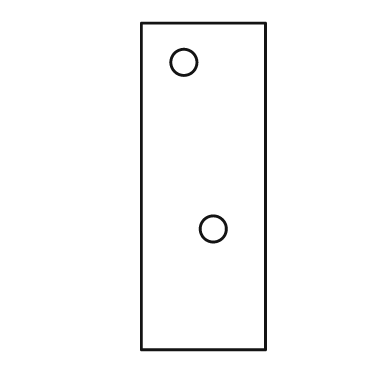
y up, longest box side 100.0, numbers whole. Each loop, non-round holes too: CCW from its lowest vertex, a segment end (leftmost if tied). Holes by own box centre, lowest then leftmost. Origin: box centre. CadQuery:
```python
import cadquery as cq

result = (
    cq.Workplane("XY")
    .moveTo(-19.0, -50.0)
    .lineTo(19.0, -50.0)
    .lineTo(19.0, 50.0)
    .lineTo(-19.0, 50.0)
    .close()
    .moveTo(3.0, -13.0)
    .circle(4.0)
    .moveTo(-6.0, 38.0)
    .circle(4.0)
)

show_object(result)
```